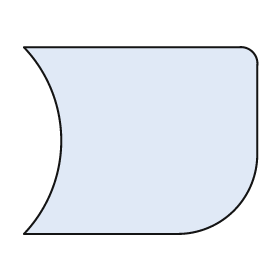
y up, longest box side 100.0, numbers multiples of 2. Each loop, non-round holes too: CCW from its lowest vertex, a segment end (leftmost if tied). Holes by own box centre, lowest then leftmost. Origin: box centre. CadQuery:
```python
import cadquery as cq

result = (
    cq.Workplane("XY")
    .moveTo(-50.0, -40.0)
    .lineTo(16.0, -40.0)
    .threePointArc((40.0, -30.0), (50.0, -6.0))
    .lineTo(50.0, 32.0)
    .threePointArc((48.0, 38.0), (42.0, 40.0))
    .lineTo(-50.0, 40.0)
    .threePointArc((-34.0, 0.0), (-50.0, -40.0))
    .close()
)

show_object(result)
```